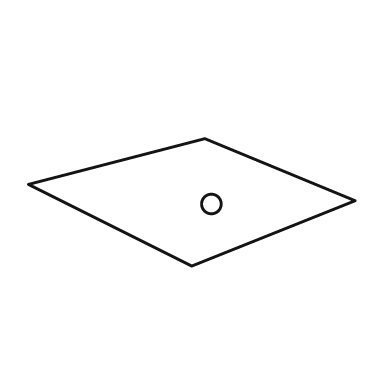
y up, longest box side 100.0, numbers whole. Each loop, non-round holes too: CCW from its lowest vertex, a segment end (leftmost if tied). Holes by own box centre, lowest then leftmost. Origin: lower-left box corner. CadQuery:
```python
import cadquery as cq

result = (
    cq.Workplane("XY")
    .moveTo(50.0, 0.0)
    .lineTo(100.0, 20.0)
    .lineTo(54.0, 39.0)
    .lineTo(0.0, 25.0)
    .close()
    .moveTo(56.0, 19.0)
    .circle(3.0)
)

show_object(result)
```